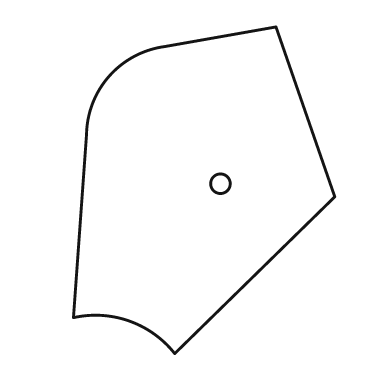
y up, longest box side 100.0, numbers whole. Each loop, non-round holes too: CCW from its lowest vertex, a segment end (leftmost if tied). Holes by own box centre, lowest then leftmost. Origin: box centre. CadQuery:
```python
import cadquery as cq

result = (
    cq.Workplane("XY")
    .moveTo(-9.0, -50.0)
    .lineTo(40.0, -2.0)
    .lineTo(22.0, 50.0)
    .lineTo(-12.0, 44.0)
    .threePointArc((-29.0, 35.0), (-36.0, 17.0))
    .lineTo(-40.0, -39.0)
    .threePointArc((-23.0, -40.0), (-9.0, -50.0))
    .close()
    .moveTo(5.0, 2.0)
    .circle(3.0)
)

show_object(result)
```